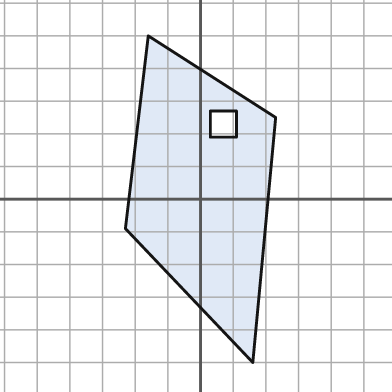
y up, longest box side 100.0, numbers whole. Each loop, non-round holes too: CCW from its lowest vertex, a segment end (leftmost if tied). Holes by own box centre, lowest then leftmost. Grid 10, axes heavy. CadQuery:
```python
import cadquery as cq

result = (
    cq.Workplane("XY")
    .moveTo(16.0, -50.0)
    .lineTo(23.0, 25.0)
    .lineTo(-16.0, 50.0)
    .lineTo(-23.0, -9.0)
    .close()
    .moveTo(3.0, 19.0)
    .lineTo(11.0, 19.0)
    .lineTo(11.0, 27.0)
    .lineTo(3.0, 27.0)
    .close()
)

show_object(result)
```